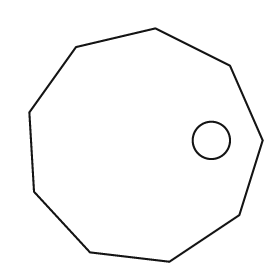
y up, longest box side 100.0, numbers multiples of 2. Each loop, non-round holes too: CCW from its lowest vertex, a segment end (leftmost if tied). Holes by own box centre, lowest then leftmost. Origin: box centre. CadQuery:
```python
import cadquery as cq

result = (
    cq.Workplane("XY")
    .moveTo(10.0, -50.0)
    .lineTo(40.0, -30.0)
    .lineTo(50.0, 2.0)
    .lineTo(36.0, 34.0)
    .lineTo(4.0, 50.0)
    .lineTo(-30.0, 42.0)
    .lineTo(-50.0, 14.0)
    .lineTo(-48.0, -20.0)
    .lineTo(-24.0, -46.0)
    .close()
    .moveTo(28.0, 2.0)
    .circle(8.0)
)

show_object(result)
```